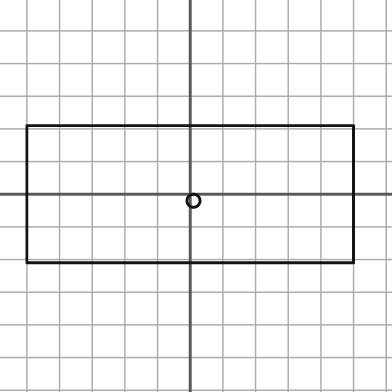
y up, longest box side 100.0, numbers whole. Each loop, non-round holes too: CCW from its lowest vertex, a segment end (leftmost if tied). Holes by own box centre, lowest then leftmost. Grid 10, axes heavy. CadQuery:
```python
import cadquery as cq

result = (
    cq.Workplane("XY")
    .moveTo(-50.0, -21.0)
    .lineTo(50.0, -21.0)
    .lineTo(50.0, 21.0)
    .lineTo(-50.0, 21.0)
    .close()
    .moveTo(1.0, -2.0)
    .circle(2.0)
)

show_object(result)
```